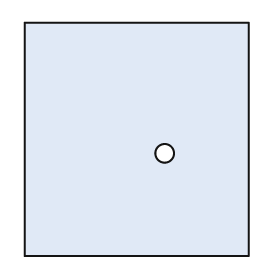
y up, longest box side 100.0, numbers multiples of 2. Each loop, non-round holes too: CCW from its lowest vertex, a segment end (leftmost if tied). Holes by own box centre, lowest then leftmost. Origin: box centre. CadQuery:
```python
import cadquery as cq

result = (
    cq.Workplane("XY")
    .moveTo(-48.0, -50.0)
    .lineTo(48.0, -50.0)
    .lineTo(48.0, 50.0)
    .lineTo(-48.0, 50.0)
    .close()
    .moveTo(12.0, -6.0)
    .circle(4.0)
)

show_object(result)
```